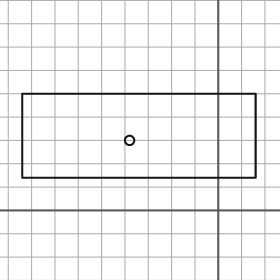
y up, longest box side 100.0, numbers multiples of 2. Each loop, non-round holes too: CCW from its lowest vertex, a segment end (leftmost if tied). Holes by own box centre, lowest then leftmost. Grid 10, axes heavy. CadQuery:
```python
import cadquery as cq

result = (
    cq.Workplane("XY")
    .moveTo(-84.0, 14.0)
    .lineTo(16.0, 14.0)
    .lineTo(16.0, 50.0)
    .lineTo(-84.0, 50.0)
    .close()
    .moveTo(-38.0, 30.0)
    .circle(2.0)
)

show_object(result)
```